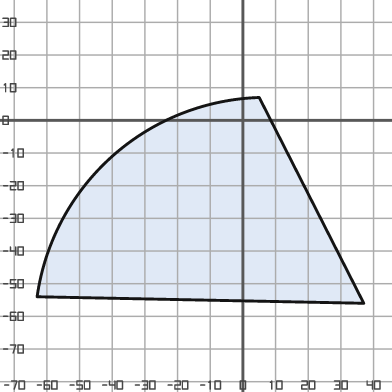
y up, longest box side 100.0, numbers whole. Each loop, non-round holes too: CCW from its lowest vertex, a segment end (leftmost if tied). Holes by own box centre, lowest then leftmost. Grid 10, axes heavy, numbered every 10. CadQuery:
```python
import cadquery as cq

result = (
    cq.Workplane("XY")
    .moveTo(37.0, -56.0)
    .lineTo(5.0, 7.0)
    .threePointArc((-40.0, -11.0), (-63.0, -54.0))
    .close()
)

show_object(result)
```